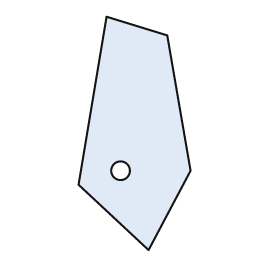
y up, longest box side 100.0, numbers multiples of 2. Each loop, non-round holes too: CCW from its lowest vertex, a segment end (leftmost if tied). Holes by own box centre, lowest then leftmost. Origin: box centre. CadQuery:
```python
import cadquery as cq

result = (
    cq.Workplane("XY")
    .moveTo(6.0, -50.0)
    .lineTo(24.0, -16.0)
    .lineTo(14.0, 42.0)
    .lineTo(-12.0, 50.0)
    .lineTo(-24.0, -22.0)
    .close()
    .moveTo(-6.0, -16.0)
    .circle(4.0)
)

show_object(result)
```